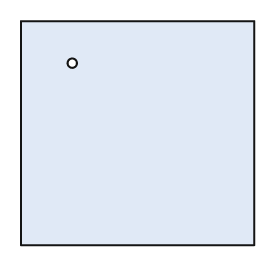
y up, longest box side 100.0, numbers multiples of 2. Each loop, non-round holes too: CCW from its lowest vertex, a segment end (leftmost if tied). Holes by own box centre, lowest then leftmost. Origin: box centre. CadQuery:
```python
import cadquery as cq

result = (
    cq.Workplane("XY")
    .moveTo(-50.0, -48.0)
    .lineTo(50.0, -48.0)
    .lineTo(50.0, 48.0)
    .lineTo(-50.0, 48.0)
    .close()
    .moveTo(-28.0, 30.0)
    .circle(2.0)
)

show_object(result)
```